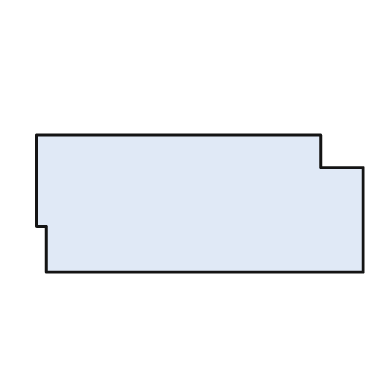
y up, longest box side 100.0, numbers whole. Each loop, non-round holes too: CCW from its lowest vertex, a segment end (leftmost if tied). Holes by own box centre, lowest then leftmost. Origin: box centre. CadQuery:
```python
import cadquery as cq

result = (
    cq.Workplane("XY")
    .moveTo(-47.0, -21.0)
    .lineTo(50.0, -21.0)
    .lineTo(50.0, 11.0)
    .lineTo(37.0, 11.0)
    .lineTo(37.0, 21.0)
    .lineTo(-50.0, 21.0)
    .lineTo(-50.0, -7.0)
    .lineTo(-47.0, -7.0)
    .close()
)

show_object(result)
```